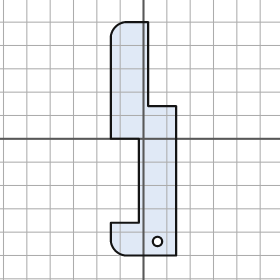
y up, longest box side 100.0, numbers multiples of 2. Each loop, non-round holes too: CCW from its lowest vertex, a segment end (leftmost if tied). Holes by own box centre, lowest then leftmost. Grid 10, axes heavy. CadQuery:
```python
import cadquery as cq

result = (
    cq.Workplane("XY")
    .moveTo(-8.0, -50.0)
    .lineTo(14.0, -50.0)
    .lineTo(14.0, 14.0)
    .lineTo(2.0, 14.0)
    .lineTo(2.0, 50.0)
    .lineTo(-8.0, 50.0)
    .threePointArc((-12.0, 48.0), (-14.0, 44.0))
    .lineTo(-14.0, 0.0)
    .lineTo(-2.0, 0.0)
    .lineTo(-2.0, -36.0)
    .lineTo(-14.0, -36.0)
    .lineTo(-14.0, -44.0)
    .threePointArc((-12.0, -48.0), (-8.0, -50.0))
    .close()
    .moveTo(6.0, -44.0)
    .circle(2.0)
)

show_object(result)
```